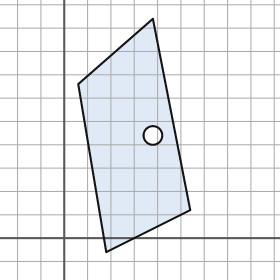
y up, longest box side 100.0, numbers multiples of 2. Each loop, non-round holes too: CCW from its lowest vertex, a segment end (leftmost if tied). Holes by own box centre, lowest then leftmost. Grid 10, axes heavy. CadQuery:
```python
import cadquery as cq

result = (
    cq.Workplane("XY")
    .moveTo(18.0, -6.0)
    .lineTo(54.0, 12.0)
    .lineTo(38.0, 94.0)
    .lineTo(6.0, 66.0)
    .close()
    .moveTo(38.0, 44.0)
    .circle(4.0)
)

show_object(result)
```